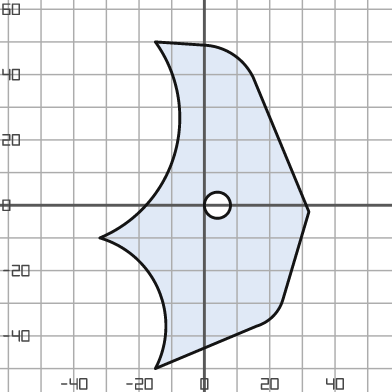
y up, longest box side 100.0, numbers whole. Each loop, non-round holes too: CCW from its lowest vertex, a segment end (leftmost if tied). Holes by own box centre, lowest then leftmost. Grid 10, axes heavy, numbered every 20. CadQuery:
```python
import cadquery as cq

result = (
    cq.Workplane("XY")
    .moveTo(-15.0, -50.0)
    .lineTo(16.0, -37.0)
    .threePointArc((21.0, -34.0), (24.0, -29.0))
    .lineTo(32.0, -2.0)
    .lineTo(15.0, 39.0)
    .threePointArc((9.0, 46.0), (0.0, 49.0))
    .lineTo(-15.0, 50.0)
    .threePointArc((-9.0, 16.0), (-32.0, -10.0))
    .threePointArc((-14.0, -26.0), (-15.0, -50.0))
    .close()
    .moveTo(4.0, 0.0)
    .circle(4.0)
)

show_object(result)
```